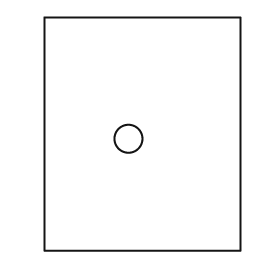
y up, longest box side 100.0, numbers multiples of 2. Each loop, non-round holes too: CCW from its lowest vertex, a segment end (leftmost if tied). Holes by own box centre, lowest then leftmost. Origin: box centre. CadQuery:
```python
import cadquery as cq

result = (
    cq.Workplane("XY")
    .moveTo(-42.0, -50.0)
    .lineTo(42.0, -50.0)
    .lineTo(42.0, 50.0)
    .lineTo(-42.0, 50.0)
    .close()
    .moveTo(-6.0, -2.0)
    .circle(6.0)
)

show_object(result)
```